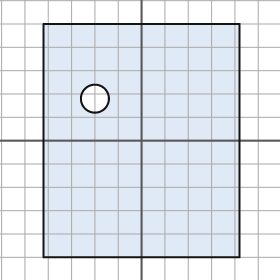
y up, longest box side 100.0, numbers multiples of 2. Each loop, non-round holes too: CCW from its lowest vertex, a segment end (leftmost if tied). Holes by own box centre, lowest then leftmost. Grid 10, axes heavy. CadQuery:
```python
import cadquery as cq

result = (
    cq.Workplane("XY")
    .moveTo(-42.0, -50.0)
    .lineTo(42.0, -50.0)
    .lineTo(42.0, 50.0)
    .lineTo(-42.0, 50.0)
    .close()
    .moveTo(-20.0, 18.0)
    .circle(6.0)
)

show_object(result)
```